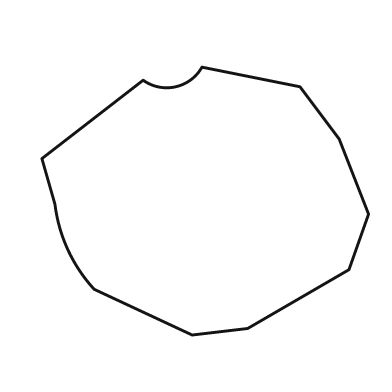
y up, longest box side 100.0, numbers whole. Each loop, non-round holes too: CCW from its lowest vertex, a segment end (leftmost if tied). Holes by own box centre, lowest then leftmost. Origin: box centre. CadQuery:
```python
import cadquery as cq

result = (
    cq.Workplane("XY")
    .moveTo(-4.0, -41.0)
    .lineTo(13.0, -39.0)
    .lineTo(44.0, -21.0)
    .lineTo(50.0, -4.0)
    .lineTo(41.0, 19.0)
    .lineTo(29.0, 35.0)
    .lineTo(-1.0, 41.0)
    .threePointArc((-9.0, 35.0), (-19.0, 37.0))
    .lineTo(-50.0, 13.0)
    .lineTo(-46.0, -1.0)
    .threePointArc((-42.0, -15.0), (-34.0, -27.0))
    .close()
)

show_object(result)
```